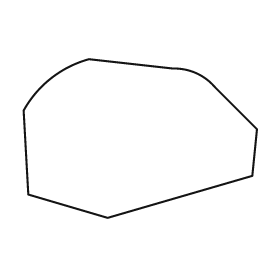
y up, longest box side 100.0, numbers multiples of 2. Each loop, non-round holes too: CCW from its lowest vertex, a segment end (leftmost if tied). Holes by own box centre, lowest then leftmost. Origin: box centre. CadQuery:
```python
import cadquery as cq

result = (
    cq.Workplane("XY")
    .moveTo(-14.0, -34.0)
    .lineTo(48.0, -16.0)
    .lineTo(50.0, 4.0)
    .lineTo(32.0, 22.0)
    .threePointArc((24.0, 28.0), (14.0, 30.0))
    .lineTo(-22.0, 34.0)
    .threePointArc((-38.0, 26.0), (-50.0, 12.0))
    .lineTo(-48.0, -24.0)
    .close()
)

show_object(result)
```